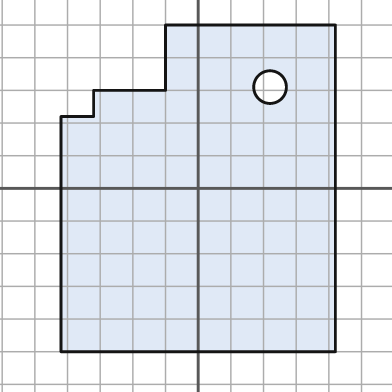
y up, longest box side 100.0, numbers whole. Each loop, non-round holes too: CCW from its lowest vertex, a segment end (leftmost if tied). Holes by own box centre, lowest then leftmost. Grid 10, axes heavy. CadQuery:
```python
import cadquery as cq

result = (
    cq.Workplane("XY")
    .moveTo(-42.0, -50.0)
    .lineTo(42.0, -50.0)
    .lineTo(42.0, 50.0)
    .lineTo(-10.0, 50.0)
    .lineTo(-10.0, 30.0)
    .lineTo(-32.0, 30.0)
    .lineTo(-32.0, 22.0)
    .lineTo(-42.0, 22.0)
    .close()
    .moveTo(22.0, 31.0)
    .circle(5.0)
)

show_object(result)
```